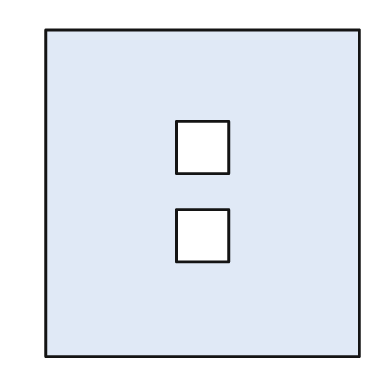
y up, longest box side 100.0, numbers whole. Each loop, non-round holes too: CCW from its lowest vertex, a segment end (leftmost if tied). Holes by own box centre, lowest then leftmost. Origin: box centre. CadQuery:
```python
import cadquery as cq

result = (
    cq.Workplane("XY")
    .moveTo(-48.0, -50.0)
    .lineTo(48.0, -50.0)
    .lineTo(48.0, 50.0)
    .lineTo(-48.0, 50.0)
    .close()
    .moveTo(-8.0, -21.0)
    .lineTo(8.0, -21.0)
    .lineTo(8.0, -5.0)
    .lineTo(-8.0, -5.0)
    .close()
    .moveTo(-8.0, 6.0)
    .lineTo(8.0, 6.0)
    .lineTo(8.0, 22.0)
    .lineTo(-8.0, 22.0)
    .close()
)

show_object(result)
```